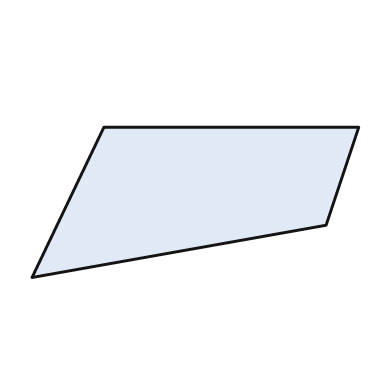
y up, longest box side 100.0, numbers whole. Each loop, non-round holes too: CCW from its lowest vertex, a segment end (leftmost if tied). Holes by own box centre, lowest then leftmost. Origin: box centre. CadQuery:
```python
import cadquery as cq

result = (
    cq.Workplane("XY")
    .moveTo(-50.0, -23.0)
    .lineTo(40.0, -7.0)
    .lineTo(50.0, 23.0)
    .lineTo(-28.0, 23.0)
    .close()
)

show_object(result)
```